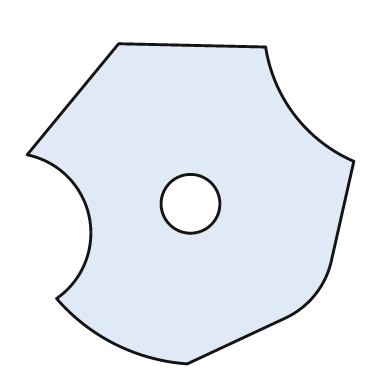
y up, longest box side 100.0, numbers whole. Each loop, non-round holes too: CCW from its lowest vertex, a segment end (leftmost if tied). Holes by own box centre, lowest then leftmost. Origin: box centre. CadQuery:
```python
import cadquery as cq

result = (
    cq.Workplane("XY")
    .moveTo(-1.0, -49.0)
    .lineTo(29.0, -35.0)
    .threePointArc((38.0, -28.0), (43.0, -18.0))
    .lineTo(50.0, 13.0)
    .threePointArc((32.0, 27.0), (23.0, 48.0))
    .lineTo(-22.0, 49.0)
    .lineTo(-50.0, 15.0)
    .threePointArc((-31.0, -4.0), (-41.0, -29.0))
    .threePointArc((-23.0, -43.0), (-1.0, -49.0))
    .close()
    .moveTo(0.0, 0.0)
    .circle(9.0)
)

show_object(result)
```